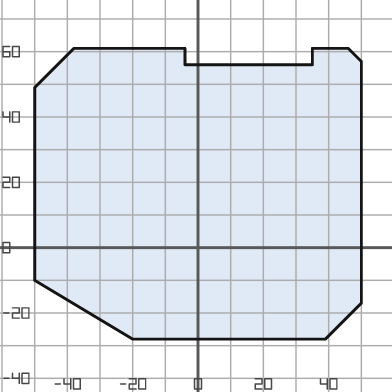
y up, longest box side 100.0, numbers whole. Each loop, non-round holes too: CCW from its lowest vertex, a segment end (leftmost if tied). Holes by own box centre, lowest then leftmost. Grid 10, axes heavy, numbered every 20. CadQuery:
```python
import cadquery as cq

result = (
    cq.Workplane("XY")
    .moveTo(-20.0, -28.0)
    .lineTo(39.0, -28.0)
    .lineTo(50.0, -17.0)
    .lineTo(50.0, 57.0)
    .lineTo(46.0, 61.0)
    .lineTo(35.0, 61.0)
    .lineTo(35.0, 56.0)
    .lineTo(-4.0, 56.0)
    .lineTo(-4.0, 61.0)
    .lineTo(-38.0, 61.0)
    .lineTo(-50.0, 49.0)
    .lineTo(-50.0, -10.0)
    .close()
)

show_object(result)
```